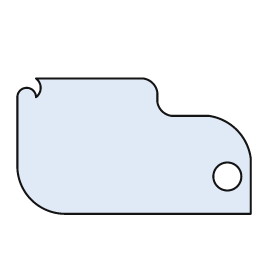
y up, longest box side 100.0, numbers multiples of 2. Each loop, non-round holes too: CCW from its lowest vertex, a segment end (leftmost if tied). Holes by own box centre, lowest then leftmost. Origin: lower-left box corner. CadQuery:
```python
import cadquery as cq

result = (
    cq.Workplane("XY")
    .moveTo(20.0, 0.0)
    .lineTo(100.0, 0.0)
    .lineTo(100.0, 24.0)
    .threePointArc((94.0, 36.0), (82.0, 42.0))
    .lineTo(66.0, 42.0)
    .threePointArc((62.0, 44.0), (60.0, 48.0))
    .lineTo(60.0, 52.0)
    .threePointArc((58.0, 56.0), (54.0, 58.0))
    .lineTo(8.0, 58.0)
    .threePointArc((10.0, 54.0), (8.0, 50.0))
    .threePointArc((4.0, 54.0), (0.0, 50.0))
    .lineTo(0.0, 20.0)
    .threePointArc((6.0, 6.0), (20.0, 0.0))
    .close()
    .moveTo(90.0, 16.0)
    .circle(6.0)
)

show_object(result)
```